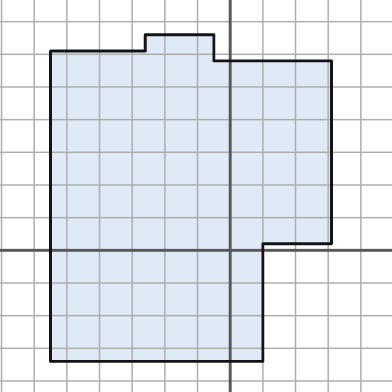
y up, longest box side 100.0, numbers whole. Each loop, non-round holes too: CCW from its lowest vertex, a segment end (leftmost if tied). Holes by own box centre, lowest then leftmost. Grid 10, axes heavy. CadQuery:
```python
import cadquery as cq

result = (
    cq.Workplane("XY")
    .moveTo(-55.0, -34.0)
    .lineTo(10.0, -34.0)
    .lineTo(10.0, 2.0)
    .lineTo(31.0, 2.0)
    .lineTo(31.0, 58.0)
    .lineTo(-5.0, 58.0)
    .lineTo(-5.0, 66.0)
    .lineTo(-26.0, 66.0)
    .lineTo(-26.0, 61.0)
    .lineTo(-55.0, 61.0)
    .close()
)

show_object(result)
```